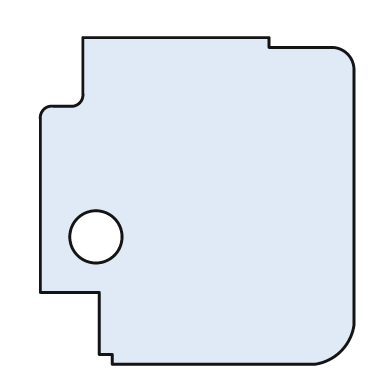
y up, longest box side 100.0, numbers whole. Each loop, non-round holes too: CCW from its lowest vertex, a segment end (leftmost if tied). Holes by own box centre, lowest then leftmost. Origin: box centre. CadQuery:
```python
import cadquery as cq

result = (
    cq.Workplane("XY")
    .moveTo(-26.0, -50.0)
    .lineTo(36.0, -50.0)
    .threePointArc((44.0, -46.0), (48.0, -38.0))
    .lineTo(48.0, 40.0)
    .threePointArc((46.0, 45.0), (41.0, 47.0))
    .lineTo(22.0, 47.0)
    .lineTo(22.0, 50.0)
    .lineTo(-35.0, 50.0)
    .lineTo(-35.0, 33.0)
    .threePointArc((-36.0, 30.0), (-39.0, 29.0))
    .lineTo(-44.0, 29.0)
    .threePointArc((-47.0, 28.0), (-48.0, 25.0))
    .lineTo(-48.0, -28.0)
    .lineTo(-30.0, -28.0)
    .lineTo(-30.0, -47.0)
    .lineTo(-26.0, -47.0)
    .close()
    .moveTo(-31.0, -11.0)
    .circle(8.0)
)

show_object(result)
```